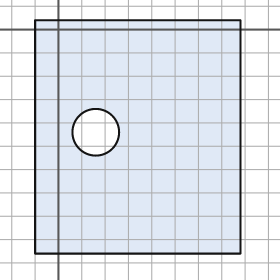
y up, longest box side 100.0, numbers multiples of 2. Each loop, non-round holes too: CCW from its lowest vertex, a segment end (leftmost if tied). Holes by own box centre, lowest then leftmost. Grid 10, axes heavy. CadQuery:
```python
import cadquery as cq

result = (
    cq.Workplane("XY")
    .moveTo(-10.0, -96.0)
    .lineTo(78.0, -96.0)
    .lineTo(78.0, 4.0)
    .lineTo(-10.0, 4.0)
    .close()
    .moveTo(16.0, -44.0)
    .circle(10.0)
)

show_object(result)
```